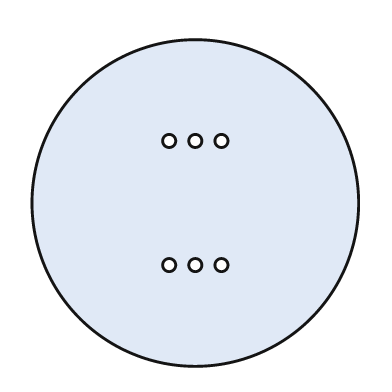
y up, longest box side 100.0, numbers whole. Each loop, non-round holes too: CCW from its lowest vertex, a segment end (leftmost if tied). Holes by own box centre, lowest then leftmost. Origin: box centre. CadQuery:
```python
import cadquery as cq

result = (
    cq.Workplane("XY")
    .moveTo(0.0, 0.0)
    .circle(50.0)
    .moveTo(-8.0, -19.0)
    .circle(2.0)
    .moveTo(0.0, -19.0)
    .circle(2.0)
    .moveTo(8.0, -19.0)
    .circle(2.0)
    .moveTo(-8.0, 19.0)
    .circle(2.0)
    .moveTo(0.0, 19.0)
    .circle(2.0)
    .moveTo(8.0, 19.0)
    .circle(2.0)
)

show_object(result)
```